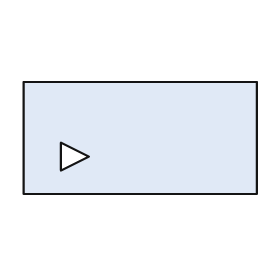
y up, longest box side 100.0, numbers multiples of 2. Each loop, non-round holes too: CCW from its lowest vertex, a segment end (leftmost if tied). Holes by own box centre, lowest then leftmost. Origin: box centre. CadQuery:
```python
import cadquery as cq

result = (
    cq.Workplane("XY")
    .moveTo(-50.0, -24.0)
    .lineTo(50.0, -24.0)
    .lineTo(50.0, 24.0)
    .lineTo(-50.0, 24.0)
    .close()
    .moveTo(-34.0, -14.0)
    .lineTo(-22.0, -8.0)
    .lineTo(-34.0, -2.0)
    .close()
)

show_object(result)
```